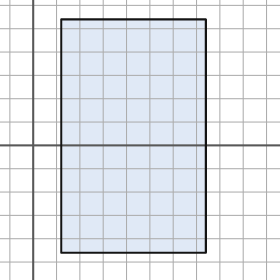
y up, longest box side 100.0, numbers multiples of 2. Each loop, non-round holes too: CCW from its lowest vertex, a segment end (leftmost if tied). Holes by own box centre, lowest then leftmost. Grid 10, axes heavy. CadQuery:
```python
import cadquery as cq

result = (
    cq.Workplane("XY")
    .moveTo(12.0, -46.0)
    .lineTo(74.0, -46.0)
    .lineTo(74.0, 54.0)
    .lineTo(12.0, 54.0)
    .close()
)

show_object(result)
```